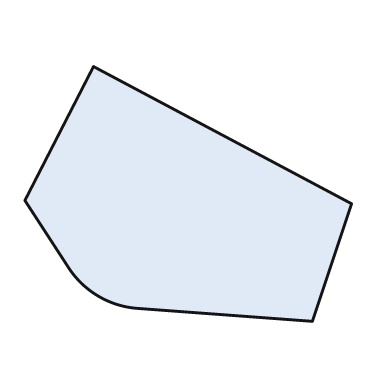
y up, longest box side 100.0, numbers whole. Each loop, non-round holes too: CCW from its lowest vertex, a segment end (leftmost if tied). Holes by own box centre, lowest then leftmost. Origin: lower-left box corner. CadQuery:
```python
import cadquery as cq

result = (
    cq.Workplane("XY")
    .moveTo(88.0, 0.0)
    .lineTo(100.0, 36.0)
    .lineTo(21.0, 78.0)
    .lineTo(0.0, 37.0)
    .lineTo(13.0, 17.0)
    .threePointArc((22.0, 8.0), (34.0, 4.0))
    .close()
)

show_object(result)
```